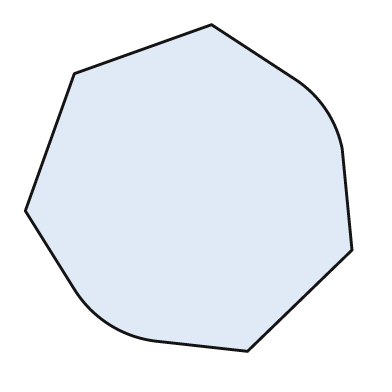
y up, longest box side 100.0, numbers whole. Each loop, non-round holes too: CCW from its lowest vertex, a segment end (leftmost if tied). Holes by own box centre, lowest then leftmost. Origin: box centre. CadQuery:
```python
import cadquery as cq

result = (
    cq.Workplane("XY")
    .moveTo(18.0, -50.0)
    .lineTo(50.0, -19.0)
    .lineTo(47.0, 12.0)
    .threePointArc((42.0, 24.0), (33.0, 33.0))
    .lineTo(7.0, 50.0)
    .lineTo(-35.0, 35.0)
    .lineTo(-50.0, -7.0)
    .lineTo(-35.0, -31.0)
    .threePointArc((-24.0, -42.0), (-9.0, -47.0))
    .close()
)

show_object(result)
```